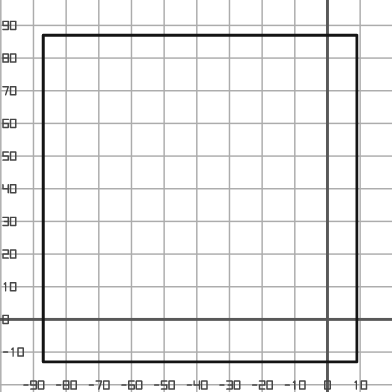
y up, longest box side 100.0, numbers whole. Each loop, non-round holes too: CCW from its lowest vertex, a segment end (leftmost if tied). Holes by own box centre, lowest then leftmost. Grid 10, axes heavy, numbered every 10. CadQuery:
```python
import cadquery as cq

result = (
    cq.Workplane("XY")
    .moveTo(-87.0, -13.0)
    .lineTo(9.0, -13.0)
    .lineTo(9.0, 87.0)
    .lineTo(-87.0, 87.0)
    .close()
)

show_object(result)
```